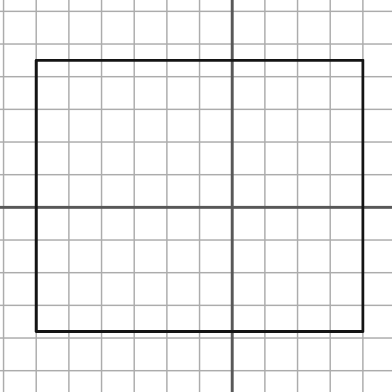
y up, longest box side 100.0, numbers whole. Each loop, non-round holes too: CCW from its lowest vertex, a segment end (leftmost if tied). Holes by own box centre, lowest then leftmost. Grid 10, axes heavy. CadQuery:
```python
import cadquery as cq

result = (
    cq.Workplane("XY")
    .moveTo(-60.0, -38.0)
    .lineTo(40.0, -38.0)
    .lineTo(40.0, 45.0)
    .lineTo(-60.0, 45.0)
    .close()
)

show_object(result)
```